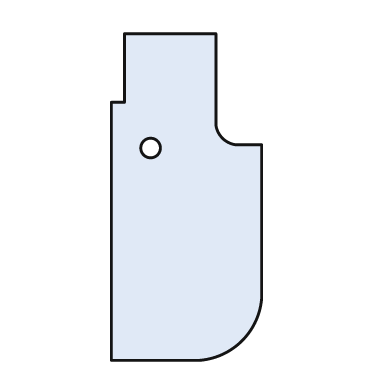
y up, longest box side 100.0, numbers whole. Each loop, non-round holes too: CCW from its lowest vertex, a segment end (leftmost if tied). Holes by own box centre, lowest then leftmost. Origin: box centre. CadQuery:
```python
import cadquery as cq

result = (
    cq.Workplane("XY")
    .moveTo(-23.0, -50.0)
    .lineTo(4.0, -50.0)
    .threePointArc((17.0, -44.0), (23.0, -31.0))
    .lineTo(23.0, 16.0)
    .lineTo(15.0, 16.0)
    .threePointArc((11.0, 18.0), (9.0, 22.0))
    .lineTo(9.0, 50.0)
    .lineTo(-19.0, 50.0)
    .lineTo(-19.0, 29.0)
    .lineTo(-23.0, 29.0)
    .close()
    .moveTo(-11.0, 15.0)
    .circle(3.0)
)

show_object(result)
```